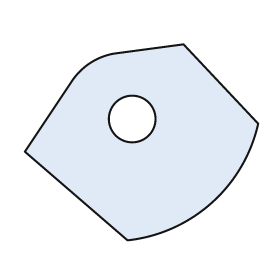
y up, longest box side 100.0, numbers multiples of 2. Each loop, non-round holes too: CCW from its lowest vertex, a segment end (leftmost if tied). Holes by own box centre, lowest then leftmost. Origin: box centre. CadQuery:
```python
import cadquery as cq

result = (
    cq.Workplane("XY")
    .moveTo(-6.0, -42.0)
    .threePointArc((30.0, -26.0), (50.0, 8.0))
    .lineTo(18.0, 42.0)
    .lineTo(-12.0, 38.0)
    .threePointArc((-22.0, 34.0), (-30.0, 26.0))
    .lineTo(-50.0, -4.0)
    .close()
    .moveTo(-4.0, 10.0)
    .circle(10.0)
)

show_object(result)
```